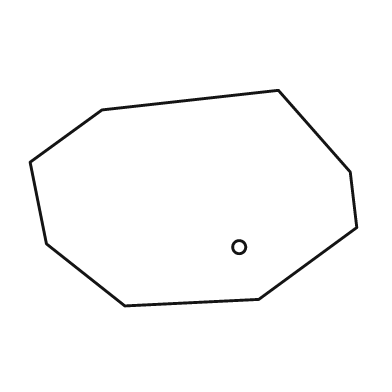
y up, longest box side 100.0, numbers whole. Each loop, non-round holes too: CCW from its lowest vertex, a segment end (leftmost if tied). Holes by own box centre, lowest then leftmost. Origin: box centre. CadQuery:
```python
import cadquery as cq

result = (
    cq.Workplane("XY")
    .moveTo(-21.0, -33.0)
    .lineTo(20.0, -31.0)
    .lineTo(50.0, -9.0)
    .lineTo(48.0, 8.0)
    .lineTo(26.0, 33.0)
    .lineTo(-28.0, 27.0)
    .lineTo(-50.0, 11.0)
    .lineTo(-45.0, -14.0)
    .close()
    .moveTo(14.0, -15.0)
    .circle(2.0)
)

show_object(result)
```